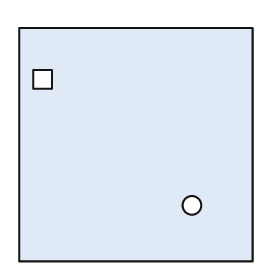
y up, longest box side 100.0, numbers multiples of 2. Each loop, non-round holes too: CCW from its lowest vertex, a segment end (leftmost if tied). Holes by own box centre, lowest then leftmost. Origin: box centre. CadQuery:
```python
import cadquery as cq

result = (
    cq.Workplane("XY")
    .moveTo(-50.0, -50.0)
    .lineTo(50.0, -50.0)
    .lineTo(50.0, 50.0)
    .lineTo(-50.0, 50.0)
    .close()
    .moveTo(24.0, -26.0)
    .circle(4.0)
    .moveTo(-44.0, 24.0)
    .lineTo(-36.0, 24.0)
    .lineTo(-36.0, 32.0)
    .lineTo(-44.0, 32.0)
    .close()
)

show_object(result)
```